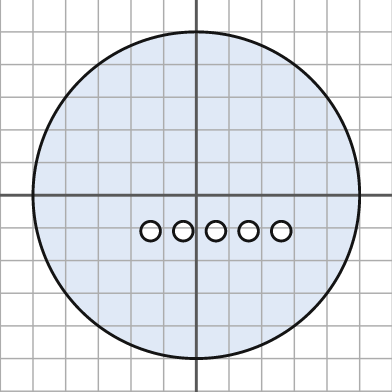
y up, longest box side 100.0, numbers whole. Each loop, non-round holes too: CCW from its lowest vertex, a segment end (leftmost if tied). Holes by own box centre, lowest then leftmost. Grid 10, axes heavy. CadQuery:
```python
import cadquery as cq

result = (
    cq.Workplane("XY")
    .moveTo(0.0, 0.0)
    .circle(50.0)
    .moveTo(-14.0, -11.0)
    .circle(3.0)
    .moveTo(-4.0, -11.0)
    .circle(3.0)
    .moveTo(6.0, -11.0)
    .circle(3.0)
    .moveTo(16.0, -11.0)
    .circle(3.0)
    .moveTo(26.0, -11.0)
    .circle(3.0)
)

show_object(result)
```